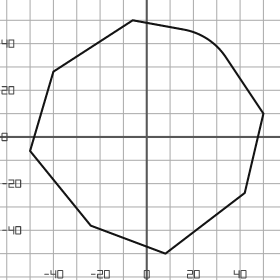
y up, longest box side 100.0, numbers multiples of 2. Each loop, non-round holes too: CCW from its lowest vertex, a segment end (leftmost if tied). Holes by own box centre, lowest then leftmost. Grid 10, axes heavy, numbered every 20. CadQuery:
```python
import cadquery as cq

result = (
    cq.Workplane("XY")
    .moveTo(8.0, -50.0)
    .lineTo(42.0, -24.0)
    .lineTo(50.0, 10.0)
    .lineTo(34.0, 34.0)
    .threePointArc((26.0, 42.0), (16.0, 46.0))
    .lineTo(-6.0, 50.0)
    .lineTo(-40.0, 28.0)
    .lineTo(-50.0, -6.0)
    .lineTo(-24.0, -38.0)
    .close()
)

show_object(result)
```